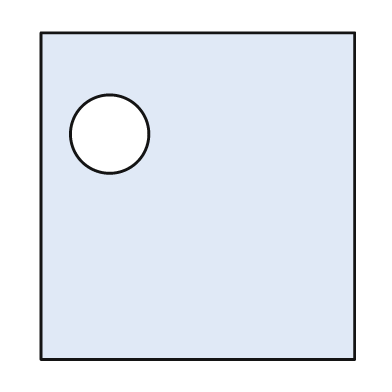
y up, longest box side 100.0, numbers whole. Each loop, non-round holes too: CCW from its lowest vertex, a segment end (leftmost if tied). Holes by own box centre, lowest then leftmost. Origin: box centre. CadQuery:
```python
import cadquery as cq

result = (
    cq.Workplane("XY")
    .moveTo(-48.0, -50.0)
    .lineTo(48.0, -50.0)
    .lineTo(48.0, 50.0)
    .lineTo(-48.0, 50.0)
    .close()
    .moveTo(-27.0, 19.0)
    .circle(12.0)
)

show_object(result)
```